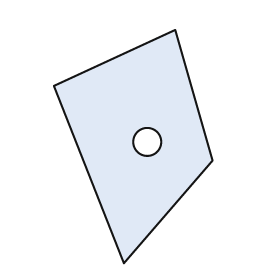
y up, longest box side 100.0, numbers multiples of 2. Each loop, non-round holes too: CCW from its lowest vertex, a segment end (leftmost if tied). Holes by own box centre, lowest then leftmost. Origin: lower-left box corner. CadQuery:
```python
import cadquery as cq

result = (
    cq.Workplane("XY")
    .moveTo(30.0, 0.0)
    .lineTo(68.0, 44.0)
    .lineTo(52.0, 100.0)
    .lineTo(0.0, 76.0)
    .close()
    .moveTo(40.0, 52.0)
    .circle(6.0)
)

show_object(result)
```